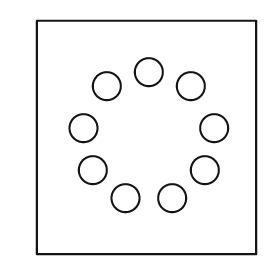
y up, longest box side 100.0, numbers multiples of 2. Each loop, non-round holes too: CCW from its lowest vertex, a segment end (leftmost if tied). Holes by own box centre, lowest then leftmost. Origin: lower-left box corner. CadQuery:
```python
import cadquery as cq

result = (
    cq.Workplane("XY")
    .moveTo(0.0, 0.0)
    .lineTo(94.0, 0.0)
    .lineTo(94.0, 100.0)
    .lineTo(0.0, 100.0)
    .close()
    .moveTo(38.0, 24.0)
    .circle(6.0)
    .moveTo(58.0, 24.0)
    .circle(6.0)
    .moveTo(24.0, 36.0)
    .circle(6.0)
    .moveTo(72.0, 36.0)
    .circle(6.0)
    .moveTo(20.0, 54.0)
    .circle(6.0)
    .moveTo(76.0, 54.0)
    .circle(6.0)
    .moveTo(30.0, 72.0)
    .circle(6.0)
    .moveTo(66.0, 72.0)
    .circle(6.0)
    .moveTo(48.0, 78.0)
    .circle(6.0)
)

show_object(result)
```